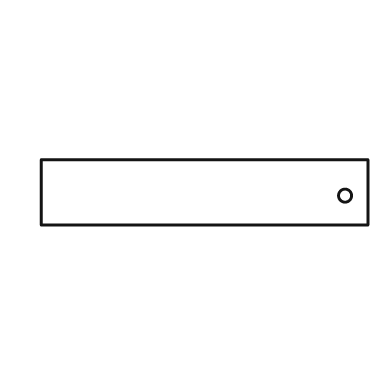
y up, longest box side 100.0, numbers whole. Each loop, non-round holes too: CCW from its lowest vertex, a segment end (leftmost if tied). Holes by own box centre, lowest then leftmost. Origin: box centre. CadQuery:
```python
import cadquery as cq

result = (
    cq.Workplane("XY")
    .moveTo(-50.0, -10.0)
    .lineTo(50.0, -10.0)
    .lineTo(50.0, 10.0)
    .lineTo(-50.0, 10.0)
    .close()
    .moveTo(43.0, -1.0)
    .circle(2.0)
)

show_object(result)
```